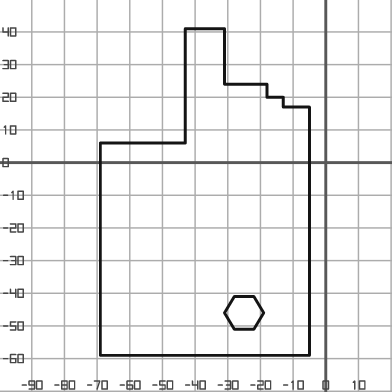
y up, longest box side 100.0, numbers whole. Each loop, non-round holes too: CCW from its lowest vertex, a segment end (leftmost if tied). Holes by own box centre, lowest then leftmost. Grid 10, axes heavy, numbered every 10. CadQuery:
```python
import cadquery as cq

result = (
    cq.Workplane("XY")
    .moveTo(-69.0, -59.0)
    .lineTo(-5.0, -59.0)
    .lineTo(-5.0, 17.0)
    .lineTo(-13.0, 17.0)
    .lineTo(-13.0, 20.0)
    .lineTo(-18.0, 20.0)
    .lineTo(-18.0, 24.0)
    .lineTo(-31.0, 24.0)
    .lineTo(-31.0, 41.0)
    .lineTo(-43.0, 41.0)
    .lineTo(-43.0, 6.0)
    .lineTo(-69.0, 6.0)
    .close()
    .moveTo(-28.0, -51.0)
    .lineTo(-22.0, -51.0)
    .lineTo(-19.0, -46.0)
    .lineTo(-22.0, -41.0)
    .lineTo(-28.0, -41.0)
    .lineTo(-31.0, -46.0)
    .close()
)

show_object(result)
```